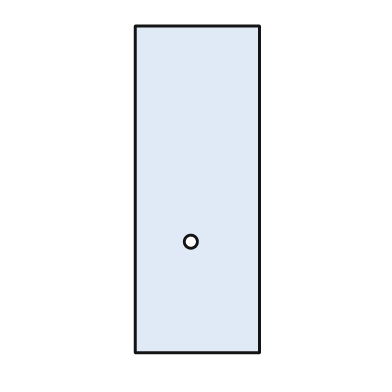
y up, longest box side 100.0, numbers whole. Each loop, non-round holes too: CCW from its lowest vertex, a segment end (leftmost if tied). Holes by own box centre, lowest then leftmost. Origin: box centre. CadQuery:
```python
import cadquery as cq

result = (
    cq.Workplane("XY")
    .moveTo(-19.0, -50.0)
    .lineTo(19.0, -50.0)
    .lineTo(19.0, 50.0)
    .lineTo(-19.0, 50.0)
    .close()
    .moveTo(-2.0, -16.0)
    .circle(2.0)
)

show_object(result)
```